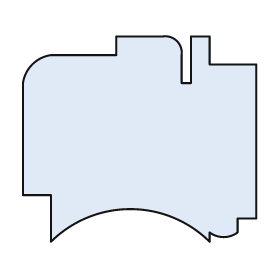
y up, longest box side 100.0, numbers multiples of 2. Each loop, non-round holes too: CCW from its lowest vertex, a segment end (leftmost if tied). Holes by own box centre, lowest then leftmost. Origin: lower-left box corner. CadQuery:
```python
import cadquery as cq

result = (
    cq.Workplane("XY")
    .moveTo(12.0, 0.0)
    .threePointArc((46.0, 14.0), (80.0, 0.0))
    .lineTo(80.0, 4.0)
    .threePointArc((86.0, 2.0), (92.0, 4.0))
    .lineTo(92.0, 10.0)
    .lineTo(100.0, 10.0)
    .lineTo(100.0, 76.0)
    .lineTo(80.0, 76.0)
    .lineTo(80.0, 88.0)
    .lineTo(72.0, 88.0)
    .lineTo(72.0, 68.0)
    .lineTo(68.0, 68.0)
    .lineTo(68.0, 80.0)
    .threePointArc((66.0, 86.0), (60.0, 88.0))
    .lineTo(40.0, 88.0)
    .lineTo(40.0, 80.0)
    .lineTo(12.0, 80.0)
    .threePointArc((4.0, 76.0), (0.0, 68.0))
    .lineTo(0.0, 20.0)
    .lineTo(12.0, 20.0)
    .close()
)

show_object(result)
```